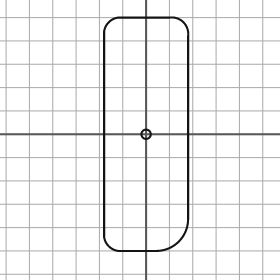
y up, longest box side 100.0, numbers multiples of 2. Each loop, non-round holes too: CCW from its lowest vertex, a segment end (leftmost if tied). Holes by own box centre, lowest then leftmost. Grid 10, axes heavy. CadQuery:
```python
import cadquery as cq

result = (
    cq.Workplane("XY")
    .moveTo(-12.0, -50.0)
    .lineTo(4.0, -50.0)
    .threePointArc((14.0, -46.0), (18.0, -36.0))
    .lineTo(18.0, 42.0)
    .threePointArc((16.0, 48.0), (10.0, 50.0))
    .lineTo(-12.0, 50.0)
    .threePointArc((-16.0, 48.0), (-18.0, 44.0))
    .lineTo(-18.0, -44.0)
    .threePointArc((-16.0, -48.0), (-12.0, -50.0))
    .close()
    .moveTo(0.0, 0.0)
    .circle(2.0)
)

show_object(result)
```